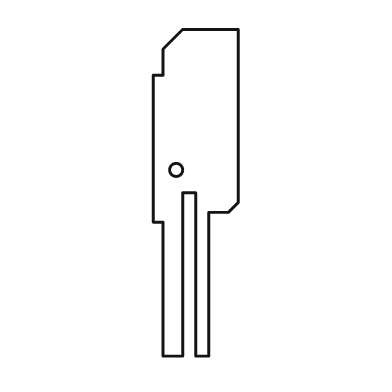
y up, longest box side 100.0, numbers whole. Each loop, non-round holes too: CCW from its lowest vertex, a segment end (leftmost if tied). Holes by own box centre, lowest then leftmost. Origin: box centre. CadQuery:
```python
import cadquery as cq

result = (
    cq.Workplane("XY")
    .moveTo(-10.0, -50.0)
    .lineTo(-4.0, -50.0)
    .lineTo(-4.0, 0.0)
    .lineTo(0.0, 0.0)
    .lineTo(0.0, -50.0)
    .lineTo(4.0, -50.0)
    .lineTo(4.0, -6.0)
    .lineTo(10.0, -6.0)
    .lineTo(13.0, -3.0)
    .lineTo(13.0, 50.0)
    .lineTo(-4.0, 50.0)
    .lineTo(-10.0, 44.0)
    .lineTo(-10.0, 36.0)
    .lineTo(-13.0, 36.0)
    .lineTo(-13.0, -9.0)
    .lineTo(-10.0, -9.0)
    .close()
    .moveTo(-6.0, 7.0)
    .circle(2.0)
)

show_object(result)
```